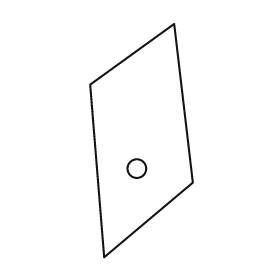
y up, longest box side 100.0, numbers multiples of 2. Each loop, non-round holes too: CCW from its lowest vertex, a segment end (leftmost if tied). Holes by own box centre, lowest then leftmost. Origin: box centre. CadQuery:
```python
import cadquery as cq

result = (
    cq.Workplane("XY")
    .moveTo(-16.0, -50.0)
    .lineTo(22.0, -18.0)
    .lineTo(14.0, 50.0)
    .lineTo(-22.0, 24.0)
    .close()
    .moveTo(-2.0, -12.0)
    .circle(4.0)
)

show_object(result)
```